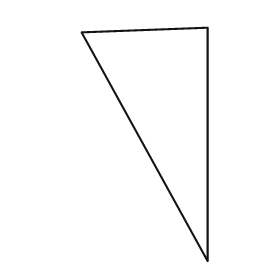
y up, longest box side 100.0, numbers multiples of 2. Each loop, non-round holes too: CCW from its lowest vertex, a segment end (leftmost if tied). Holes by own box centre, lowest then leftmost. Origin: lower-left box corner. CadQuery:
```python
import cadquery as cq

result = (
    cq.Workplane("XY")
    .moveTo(54.0, 0.0)
    .lineTo(54.0, 100.0)
    .lineTo(0.0, 98.0)
    .close()
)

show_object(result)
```